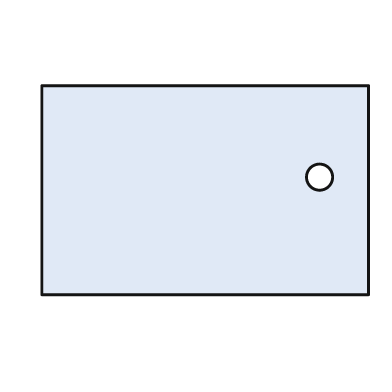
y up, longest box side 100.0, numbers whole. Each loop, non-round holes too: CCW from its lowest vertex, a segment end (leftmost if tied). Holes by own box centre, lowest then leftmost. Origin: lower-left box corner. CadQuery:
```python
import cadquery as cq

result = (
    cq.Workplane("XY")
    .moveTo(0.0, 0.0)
    .lineTo(100.0, 0.0)
    .lineTo(100.0, 64.0)
    .lineTo(0.0, 64.0)
    .close()
    .moveTo(85.0, 36.0)
    .circle(4.0)
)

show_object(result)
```